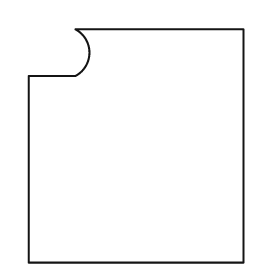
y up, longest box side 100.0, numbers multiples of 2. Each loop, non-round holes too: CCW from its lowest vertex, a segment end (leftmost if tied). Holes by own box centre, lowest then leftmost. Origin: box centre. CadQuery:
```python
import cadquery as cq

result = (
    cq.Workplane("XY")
    .moveTo(-46.0, -50.0)
    .lineTo(46.0, -50.0)
    .lineTo(46.0, 50.0)
    .lineTo(-26.0, 50.0)
    .threePointArc((-20.0, 40.0), (-26.0, 30.0))
    .lineTo(-46.0, 30.0)
    .close()
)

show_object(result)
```